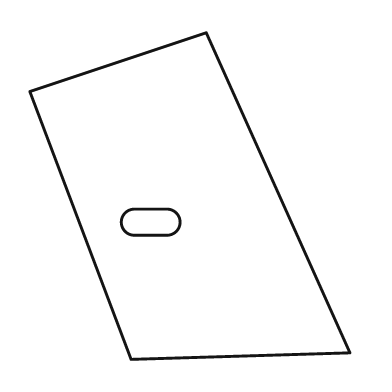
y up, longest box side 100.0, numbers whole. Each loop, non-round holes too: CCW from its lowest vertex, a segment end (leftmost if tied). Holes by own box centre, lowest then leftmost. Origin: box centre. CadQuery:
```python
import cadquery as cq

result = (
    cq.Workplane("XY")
    .moveTo(-18.0, -50.0)
    .lineTo(49.0, -48.0)
    .lineTo(5.0, 50.0)
    .lineTo(-49.0, 32.0)
    .close()
    .moveTo(-17.0, -12.0)
    .lineTo(-7.0, -12.0)
    .threePointArc((-3.0, -8.0), (-7.0, -4.0))
    .lineTo(-17.0, -4.0)
    .threePointArc((-21.0, -8.0), (-17.0, -12.0))
    .close()
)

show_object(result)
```